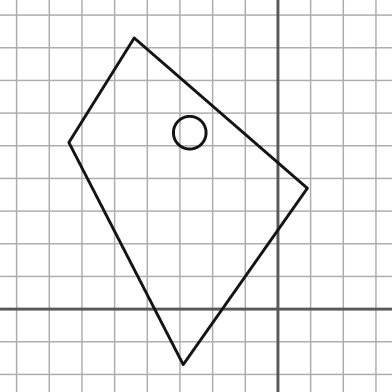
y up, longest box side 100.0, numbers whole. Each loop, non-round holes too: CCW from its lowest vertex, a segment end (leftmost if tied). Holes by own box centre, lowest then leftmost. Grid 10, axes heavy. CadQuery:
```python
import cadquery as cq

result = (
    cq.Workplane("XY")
    .moveTo(-29.0, -17.0)
    .lineTo(9.0, 37.0)
    .lineTo(-44.0, 83.0)
    .lineTo(-64.0, 51.0)
    .close()
    .moveTo(-27.0, 54.0)
    .circle(5.0)
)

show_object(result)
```